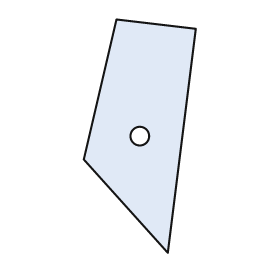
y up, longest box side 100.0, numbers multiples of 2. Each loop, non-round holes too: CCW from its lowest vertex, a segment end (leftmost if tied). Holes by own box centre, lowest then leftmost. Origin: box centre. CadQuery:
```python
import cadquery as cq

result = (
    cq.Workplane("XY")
    .moveTo(12.0, -50.0)
    .lineTo(24.0, 46.0)
    .lineTo(-10.0, 50.0)
    .lineTo(-24.0, -10.0)
    .close()
    .moveTo(0.0, 0.0)
    .circle(4.0)
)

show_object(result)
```